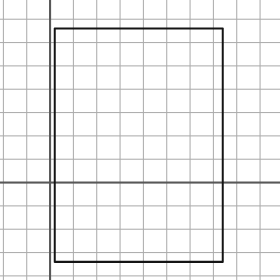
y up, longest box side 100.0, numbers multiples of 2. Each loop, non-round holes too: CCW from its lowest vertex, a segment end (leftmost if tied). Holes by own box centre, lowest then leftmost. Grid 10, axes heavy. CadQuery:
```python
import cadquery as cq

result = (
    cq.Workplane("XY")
    .moveTo(2.0, -34.0)
    .lineTo(74.0, -34.0)
    .lineTo(74.0, 66.0)
    .lineTo(2.0, 66.0)
    .close()
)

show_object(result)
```